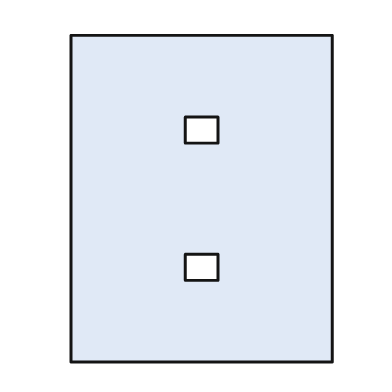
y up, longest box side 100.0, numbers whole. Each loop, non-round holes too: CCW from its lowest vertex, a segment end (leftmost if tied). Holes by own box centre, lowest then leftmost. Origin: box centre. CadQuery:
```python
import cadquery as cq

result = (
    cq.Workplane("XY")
    .moveTo(-40.0, -50.0)
    .lineTo(40.0, -50.0)
    .lineTo(40.0, 50.0)
    .lineTo(-40.0, 50.0)
    .close()
    .moveTo(-5.0, -25.0)
    .lineTo(5.0, -25.0)
    .lineTo(5.0, -17.0)
    .lineTo(-5.0, -17.0)
    .close()
    .moveTo(-5.0, 17.0)
    .lineTo(5.0, 17.0)
    .lineTo(5.0, 25.0)
    .lineTo(-5.0, 25.0)
    .close()
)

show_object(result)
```